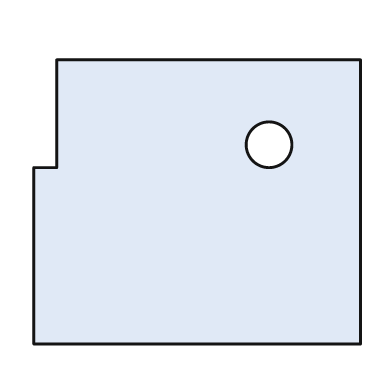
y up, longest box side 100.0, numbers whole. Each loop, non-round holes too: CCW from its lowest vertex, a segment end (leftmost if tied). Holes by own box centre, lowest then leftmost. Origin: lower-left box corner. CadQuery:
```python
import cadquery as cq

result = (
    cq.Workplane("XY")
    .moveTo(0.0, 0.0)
    .lineTo(100.0, 0.0)
    .lineTo(100.0, 87.0)
    .lineTo(7.0, 87.0)
    .lineTo(7.0, 54.0)
    .lineTo(0.0, 54.0)
    .close()
    .moveTo(72.0, 61.0)
    .circle(7.0)
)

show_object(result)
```